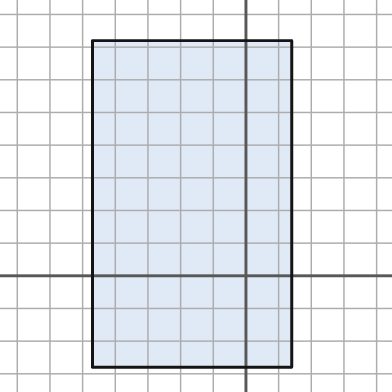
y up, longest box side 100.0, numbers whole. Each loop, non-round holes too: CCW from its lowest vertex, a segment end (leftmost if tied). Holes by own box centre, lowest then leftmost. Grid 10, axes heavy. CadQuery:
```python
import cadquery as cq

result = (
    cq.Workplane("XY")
    .moveTo(-47.0, -28.0)
    .lineTo(14.0, -28.0)
    .lineTo(14.0, 72.0)
    .lineTo(-47.0, 72.0)
    .close()
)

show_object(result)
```